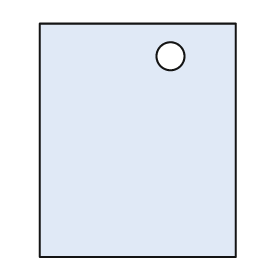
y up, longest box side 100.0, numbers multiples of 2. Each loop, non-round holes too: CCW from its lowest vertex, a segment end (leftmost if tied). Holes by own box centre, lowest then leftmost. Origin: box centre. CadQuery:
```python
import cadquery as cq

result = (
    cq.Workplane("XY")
    .moveTo(-42.0, -50.0)
    .lineTo(42.0, -50.0)
    .lineTo(42.0, 50.0)
    .lineTo(-42.0, 50.0)
    .close()
    .moveTo(14.0, 36.0)
    .circle(6.0)
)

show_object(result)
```